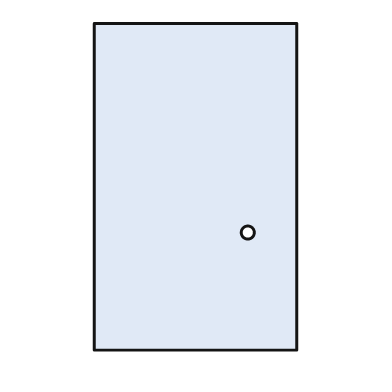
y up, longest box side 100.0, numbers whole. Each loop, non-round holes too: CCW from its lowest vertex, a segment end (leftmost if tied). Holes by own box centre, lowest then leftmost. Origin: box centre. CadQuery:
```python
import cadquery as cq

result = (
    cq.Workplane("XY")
    .moveTo(-31.0, -50.0)
    .lineTo(31.0, -50.0)
    .lineTo(31.0, 50.0)
    .lineTo(-31.0, 50.0)
    .close()
    .moveTo(16.0, -14.0)
    .circle(2.0)
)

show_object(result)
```